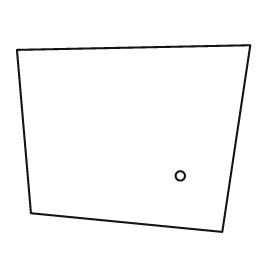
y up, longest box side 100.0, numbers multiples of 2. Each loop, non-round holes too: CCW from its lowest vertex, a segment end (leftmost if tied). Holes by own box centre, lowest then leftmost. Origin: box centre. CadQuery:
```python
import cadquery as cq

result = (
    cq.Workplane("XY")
    .moveTo(38.0, -40.0)
    .lineTo(50.0, 40.0)
    .lineTo(-50.0, 38.0)
    .lineTo(-44.0, -32.0)
    .close()
    .moveTo(20.0, -16.0)
    .circle(2.0)
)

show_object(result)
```